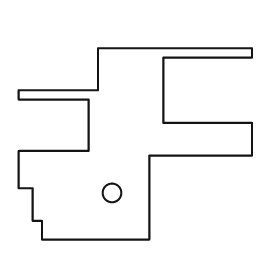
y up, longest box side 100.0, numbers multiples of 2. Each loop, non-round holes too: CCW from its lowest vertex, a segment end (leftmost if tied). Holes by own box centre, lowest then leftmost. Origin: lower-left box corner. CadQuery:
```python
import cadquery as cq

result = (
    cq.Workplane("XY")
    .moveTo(10.0, 0.0)
    .lineTo(56.0, 0.0)
    .lineTo(56.0, 36.0)
    .lineTo(100.0, 36.0)
    .lineTo(100.0, 50.0)
    .lineTo(62.0, 50.0)
    .lineTo(62.0, 78.0)
    .lineTo(100.0, 78.0)
    .lineTo(100.0, 82.0)
    .lineTo(34.0, 82.0)
    .lineTo(34.0, 64.0)
    .lineTo(0.0, 64.0)
    .lineTo(0.0, 60.0)
    .lineTo(30.0, 60.0)
    .lineTo(30.0, 38.0)
    .lineTo(0.0, 38.0)
    .lineTo(0.0, 22.0)
    .lineTo(6.0, 22.0)
    .lineTo(6.0, 8.0)
    .lineTo(10.0, 8.0)
    .close()
    .moveTo(40.0, 20.0)
    .circle(4.0)
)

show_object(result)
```